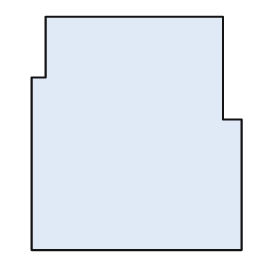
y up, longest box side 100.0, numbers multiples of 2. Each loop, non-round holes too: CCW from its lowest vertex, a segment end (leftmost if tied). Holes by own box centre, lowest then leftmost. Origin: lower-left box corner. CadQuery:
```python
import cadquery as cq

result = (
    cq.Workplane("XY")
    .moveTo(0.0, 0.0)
    .lineTo(90.0, 0.0)
    .lineTo(90.0, 56.0)
    .lineTo(82.0, 56.0)
    .lineTo(82.0, 100.0)
    .lineTo(6.0, 100.0)
    .lineTo(6.0, 74.0)
    .lineTo(0.0, 74.0)
    .close()
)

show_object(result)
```